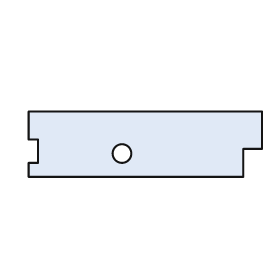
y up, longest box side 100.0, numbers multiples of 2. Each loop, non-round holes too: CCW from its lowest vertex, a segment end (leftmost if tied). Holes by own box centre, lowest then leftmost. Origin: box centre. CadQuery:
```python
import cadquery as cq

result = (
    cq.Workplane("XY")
    .moveTo(-50.0, -14.0)
    .lineTo(42.0, -14.0)
    .lineTo(42.0, -2.0)
    .lineTo(50.0, -2.0)
    .lineTo(50.0, 14.0)
    .lineTo(-50.0, 14.0)
    .lineTo(-50.0, 2.0)
    .lineTo(-46.0, 2.0)
    .lineTo(-46.0, -8.0)
    .lineTo(-50.0, -8.0)
    .close()
    .moveTo(-10.0, -4.0)
    .circle(4.0)
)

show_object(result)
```